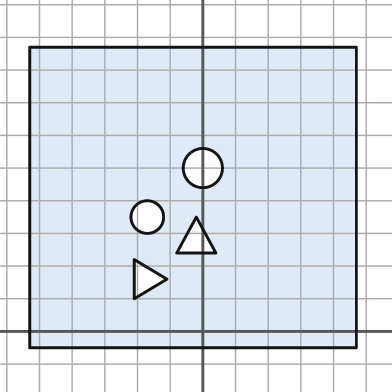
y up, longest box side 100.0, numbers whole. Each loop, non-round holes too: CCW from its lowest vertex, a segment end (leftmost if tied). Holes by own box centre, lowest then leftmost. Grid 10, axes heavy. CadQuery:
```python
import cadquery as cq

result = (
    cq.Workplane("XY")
    .moveTo(-53.0, -5.0)
    .lineTo(47.0, -5.0)
    .lineTo(47.0, 87.0)
    .lineTo(-53.0, 87.0)
    .close()
    .moveTo(-21.0, 10.0)
    .lineTo(-11.0, 16.0)
    .lineTo(-21.0, 22.0)
    .close()
    .moveTo(-8.0, 24.0)
    .lineTo(4.0, 24.0)
    .lineTo(-2.0, 35.0)
    .close()
    .moveTo(-17.0, 35.0)
    .circle(5.0)
    .moveTo(0.0, 50.0)
    .circle(6.0)
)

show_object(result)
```